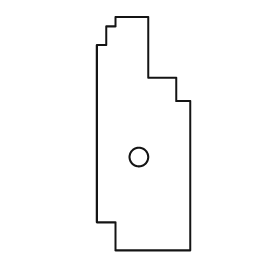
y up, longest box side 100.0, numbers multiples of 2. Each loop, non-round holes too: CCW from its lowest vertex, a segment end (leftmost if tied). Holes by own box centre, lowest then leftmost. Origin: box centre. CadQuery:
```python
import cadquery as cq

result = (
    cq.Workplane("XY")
    .moveTo(-12.0, -50.0)
    .lineTo(20.0, -50.0)
    .lineTo(20.0, 14.0)
    .lineTo(14.0, 14.0)
    .lineTo(14.0, 24.0)
    .lineTo(2.0, 24.0)
    .lineTo(2.0, 50.0)
    .lineTo(-12.0, 50.0)
    .lineTo(-12.0, 46.0)
    .lineTo(-16.0, 46.0)
    .lineTo(-16.0, 38.0)
    .lineTo(-20.0, 38.0)
    .lineTo(-20.0, -38.0)
    .lineTo(-12.0, -38.0)
    .close()
    .moveTo(-2.0, -10.0)
    .circle(4.0)
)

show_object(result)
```